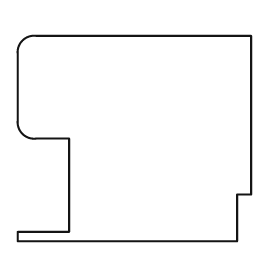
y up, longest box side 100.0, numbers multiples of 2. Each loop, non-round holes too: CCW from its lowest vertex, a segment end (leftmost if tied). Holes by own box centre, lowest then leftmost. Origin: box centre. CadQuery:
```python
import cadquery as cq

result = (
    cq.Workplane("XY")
    .moveTo(-50.0, -44.0)
    .lineTo(44.0, -44.0)
    .lineTo(44.0, -24.0)
    .lineTo(50.0, -24.0)
    .lineTo(50.0, 44.0)
    .lineTo(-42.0, 44.0)
    .threePointArc((-48.0, 42.0), (-50.0, 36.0))
    .lineTo(-50.0, 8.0)
    .threePointArc((-48.0, 2.0), (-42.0, 0.0))
    .lineTo(-28.0, 0.0)
    .lineTo(-28.0, -40.0)
    .lineTo(-50.0, -40.0)
    .close()
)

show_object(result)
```